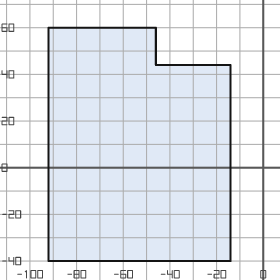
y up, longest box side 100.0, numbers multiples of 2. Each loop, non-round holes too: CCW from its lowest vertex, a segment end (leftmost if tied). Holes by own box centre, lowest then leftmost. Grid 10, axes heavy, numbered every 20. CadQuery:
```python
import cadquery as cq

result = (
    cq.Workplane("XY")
    .moveTo(-92.0, -40.0)
    .lineTo(-14.0, -40.0)
    .lineTo(-14.0, 44.0)
    .lineTo(-46.0, 44.0)
    .lineTo(-46.0, 60.0)
    .lineTo(-92.0, 60.0)
    .close()
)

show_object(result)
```